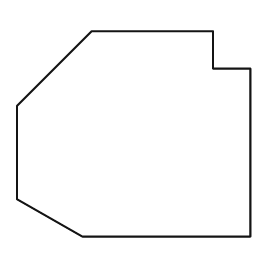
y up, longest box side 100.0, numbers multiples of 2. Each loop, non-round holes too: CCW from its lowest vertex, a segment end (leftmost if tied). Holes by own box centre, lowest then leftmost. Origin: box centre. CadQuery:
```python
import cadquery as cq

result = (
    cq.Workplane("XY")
    .moveTo(-22.0, -44.0)
    .lineTo(50.0, -44.0)
    .lineTo(50.0, 28.0)
    .lineTo(34.0, 28.0)
    .lineTo(34.0, 44.0)
    .lineTo(-18.0, 44.0)
    .lineTo(-50.0, 12.0)
    .lineTo(-50.0, -28.0)
    .close()
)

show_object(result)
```